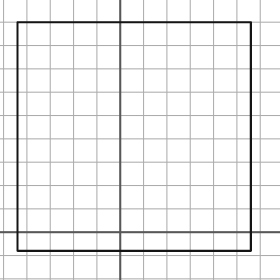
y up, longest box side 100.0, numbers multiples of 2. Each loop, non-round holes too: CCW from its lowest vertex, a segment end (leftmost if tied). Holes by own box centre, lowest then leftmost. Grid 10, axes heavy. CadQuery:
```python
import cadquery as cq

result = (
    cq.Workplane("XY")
    .moveTo(-44.0, -8.0)
    .lineTo(56.0, -8.0)
    .lineTo(56.0, 90.0)
    .lineTo(-44.0, 90.0)
    .close()
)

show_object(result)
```